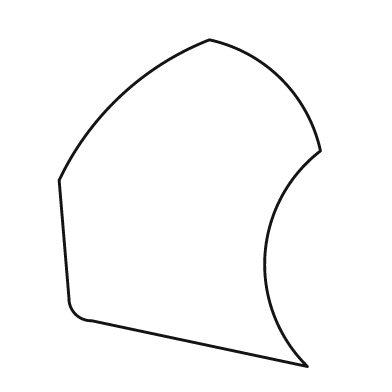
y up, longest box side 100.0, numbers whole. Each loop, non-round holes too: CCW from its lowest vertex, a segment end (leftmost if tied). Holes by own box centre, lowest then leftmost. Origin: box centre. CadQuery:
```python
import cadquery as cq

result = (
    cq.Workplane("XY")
    .moveTo(36.0, -50.0)
    .threePointArc((23.0, -16.0), (40.0, 16.0))
    .threePointArc((28.0, 38.0), (6.0, 50.0))
    .threePointArc((-21.0, 33.0), (-40.0, 7.0))
    .lineTo(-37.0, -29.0)
    .threePointArc((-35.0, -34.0), (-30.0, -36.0))
    .close()
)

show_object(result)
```